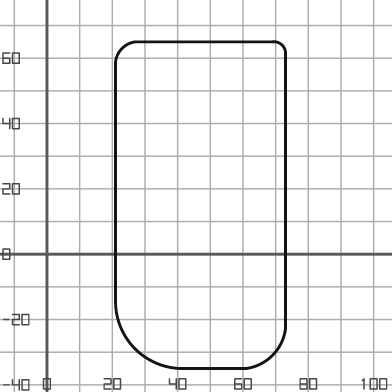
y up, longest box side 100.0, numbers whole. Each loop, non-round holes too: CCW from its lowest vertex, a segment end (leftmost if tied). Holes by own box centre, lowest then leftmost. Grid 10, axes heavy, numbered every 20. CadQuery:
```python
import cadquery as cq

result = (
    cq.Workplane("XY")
    .moveTo(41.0, -35.0)
    .lineTo(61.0, -35.0)
    .threePointArc((69.0, -31.0), (73.0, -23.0))
    .lineTo(73.0, 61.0)
    .threePointArc((72.0, 64.0), (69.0, 65.0))
    .lineTo(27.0, 65.0)
    .threePointArc((23.0, 63.0), (21.0, 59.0))
    .lineTo(21.0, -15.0)
    .threePointArc((27.0, -29.0), (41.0, -35.0))
    .close()
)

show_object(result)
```